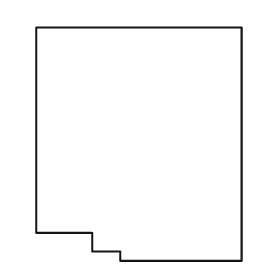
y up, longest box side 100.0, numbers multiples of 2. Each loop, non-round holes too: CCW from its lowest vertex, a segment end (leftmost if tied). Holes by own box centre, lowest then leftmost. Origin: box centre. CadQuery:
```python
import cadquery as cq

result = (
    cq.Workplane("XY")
    .moveTo(-8.0, -50.0)
    .lineTo(44.0, -50.0)
    .lineTo(44.0, 50.0)
    .lineTo(-44.0, 50.0)
    .lineTo(-44.0, -38.0)
    .lineTo(-20.0, -38.0)
    .lineTo(-20.0, -46.0)
    .lineTo(-8.0, -46.0)
    .close()
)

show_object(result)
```